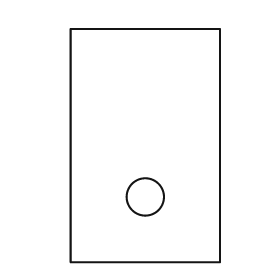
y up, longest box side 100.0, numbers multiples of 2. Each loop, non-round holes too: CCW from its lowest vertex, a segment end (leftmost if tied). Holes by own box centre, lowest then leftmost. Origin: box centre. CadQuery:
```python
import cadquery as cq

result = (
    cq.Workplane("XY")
    .moveTo(-32.0, -50.0)
    .lineTo(32.0, -50.0)
    .lineTo(32.0, 50.0)
    .lineTo(-32.0, 50.0)
    .close()
    .moveTo(0.0, -22.0)
    .circle(8.0)
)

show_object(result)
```